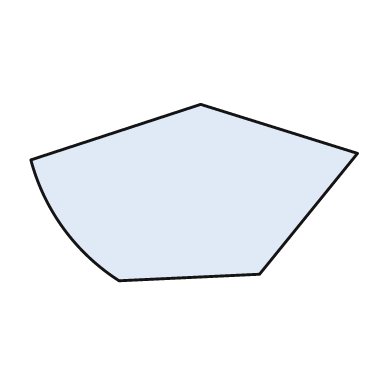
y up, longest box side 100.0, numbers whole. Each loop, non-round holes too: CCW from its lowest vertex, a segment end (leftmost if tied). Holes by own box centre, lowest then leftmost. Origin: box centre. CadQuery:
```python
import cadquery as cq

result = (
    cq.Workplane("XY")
    .moveTo(-23.0, -27.0)
    .lineTo(20.0, -25.0)
    .lineTo(50.0, 12.0)
    .lineTo(2.0, 27.0)
    .lineTo(-50.0, 10.0)
    .threePointArc((-40.0, -11.0), (-23.0, -27.0))
    .close()
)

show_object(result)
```